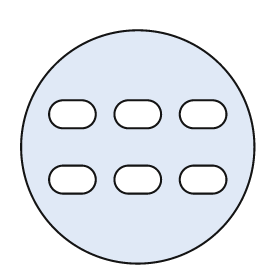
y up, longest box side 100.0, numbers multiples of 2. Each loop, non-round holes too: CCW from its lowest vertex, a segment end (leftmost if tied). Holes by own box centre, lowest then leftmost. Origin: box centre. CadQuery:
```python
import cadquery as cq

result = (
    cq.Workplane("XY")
    .moveTo(0.0, 0.0)
    .circle(50.0)
    .moveTo(-32.0, -20.0)
    .lineTo(-24.0, -20.0)
    .threePointArc((-18.0, -14.0), (-24.0, -8.0))
    .lineTo(-32.0, -8.0)
    .threePointArc((-38.0, -14.0), (-32.0, -20.0))
    .close()
    .moveTo(-4.0, -20.0)
    .lineTo(4.0, -20.0)
    .threePointArc((10.0, -14.0), (4.0, -8.0))
    .lineTo(-4.0, -8.0)
    .threePointArc((-10.0, -14.0), (-4.0, -20.0))
    .close()
    .moveTo(24.0, -20.0)
    .lineTo(32.0, -20.0)
    .threePointArc((38.0, -14.0), (32.0, -8.0))
    .lineTo(24.0, -8.0)
    .threePointArc((18.0, -14.0), (24.0, -20.0))
    .close()
    .moveTo(-32.0, 8.0)
    .lineTo(-24.0, 8.0)
    .threePointArc((-18.0, 14.0), (-24.0, 20.0))
    .lineTo(-32.0, 20.0)
    .threePointArc((-38.0, 14.0), (-32.0, 8.0))
    .close()
    .moveTo(-4.0, 8.0)
    .lineTo(4.0, 8.0)
    .threePointArc((10.0, 14.0), (4.0, 20.0))
    .lineTo(-4.0, 20.0)
    .threePointArc((-10.0, 14.0), (-4.0, 8.0))
    .close()
    .moveTo(24.0, 8.0)
    .lineTo(32.0, 8.0)
    .threePointArc((38.0, 14.0), (32.0, 20.0))
    .lineTo(24.0, 20.0)
    .threePointArc((18.0, 14.0), (24.0, 8.0))
    .close()
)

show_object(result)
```